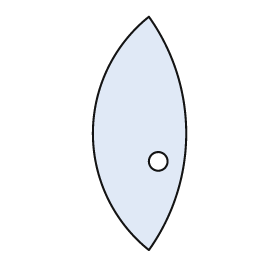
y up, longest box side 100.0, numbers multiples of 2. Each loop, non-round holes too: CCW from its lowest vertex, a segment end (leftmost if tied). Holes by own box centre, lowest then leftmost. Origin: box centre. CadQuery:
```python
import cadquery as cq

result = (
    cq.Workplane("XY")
    .moveTo(4.0, -50.0)
    .threePointArc((20.0, 0.0), (4.0, 50.0))
    .threePointArc((-20.0, 0.0), (4.0, -50.0))
    .close()
    .moveTo(8.0, -12.0)
    .circle(4.0)
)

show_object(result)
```